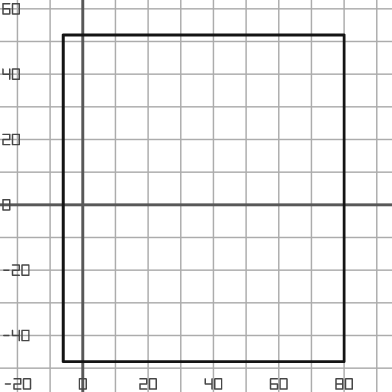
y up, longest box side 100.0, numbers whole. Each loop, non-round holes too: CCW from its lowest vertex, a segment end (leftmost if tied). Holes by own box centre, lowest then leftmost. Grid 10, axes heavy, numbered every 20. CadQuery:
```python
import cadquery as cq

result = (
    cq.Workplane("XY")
    .moveTo(-6.0, -48.0)
    .lineTo(80.0, -48.0)
    .lineTo(80.0, 52.0)
    .lineTo(-6.0, 52.0)
    .close()
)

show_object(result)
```